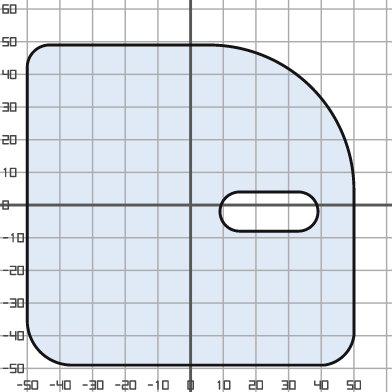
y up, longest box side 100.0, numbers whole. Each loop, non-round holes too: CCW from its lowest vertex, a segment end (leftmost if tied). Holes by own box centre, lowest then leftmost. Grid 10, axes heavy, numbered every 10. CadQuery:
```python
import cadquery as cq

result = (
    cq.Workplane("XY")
    .moveTo(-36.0, -49.0)
    .lineTo(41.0, -49.0)
    .threePointArc((47.0, -46.0), (50.0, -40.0))
    .lineTo(50.0, 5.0)
    .threePointArc((37.0, 36.0), (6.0, 49.0))
    .lineTo(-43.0, 49.0)
    .threePointArc((-48.0, 47.0), (-50.0, 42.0))
    .lineTo(-50.0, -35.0)
    .threePointArc((-46.0, -45.0), (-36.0, -49.0))
    .close()
    .moveTo(15.0, -8.0)
    .lineTo(33.0, -8.0)
    .threePointArc((39.0, -2.0), (33.0, 4.0))
    .lineTo(15.0, 4.0)
    .threePointArc((9.0, -2.0), (15.0, -8.0))
    .close()
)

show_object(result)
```